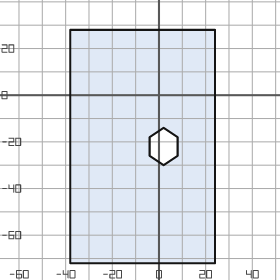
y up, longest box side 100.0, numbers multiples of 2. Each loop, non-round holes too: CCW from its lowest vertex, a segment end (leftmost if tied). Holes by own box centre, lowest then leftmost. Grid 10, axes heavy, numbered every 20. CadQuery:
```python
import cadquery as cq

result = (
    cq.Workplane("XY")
    .moveTo(-38.0, -72.0)
    .lineTo(24.0, -72.0)
    .lineTo(24.0, 28.0)
    .lineTo(-38.0, 28.0)
    .close()
    .moveTo(2.0, -30.0)
    .lineTo(8.0, -26.0)
    .lineTo(8.0, -18.0)
    .lineTo(2.0, -14.0)
    .lineTo(-4.0, -18.0)
    .lineTo(-4.0, -26.0)
    .close()
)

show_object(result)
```